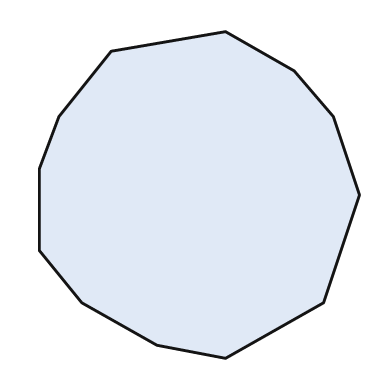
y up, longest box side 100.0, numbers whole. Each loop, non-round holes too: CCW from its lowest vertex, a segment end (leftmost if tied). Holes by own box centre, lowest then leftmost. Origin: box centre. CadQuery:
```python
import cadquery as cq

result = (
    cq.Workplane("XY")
    .moveTo(8.0, -50.0)
    .lineTo(38.0, -33.0)
    .lineTo(49.0, 0.0)
    .lineTo(41.0, 24.0)
    .lineTo(29.0, 38.0)
    .lineTo(8.0, 50.0)
    .lineTo(-27.0, 44.0)
    .lineTo(-43.0, 24.0)
    .lineTo(-49.0, 8.0)
    .lineTo(-49.0, -17.0)
    .lineTo(-36.0, -33.0)
    .lineTo(-13.0, -46.0)
    .close()
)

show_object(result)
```